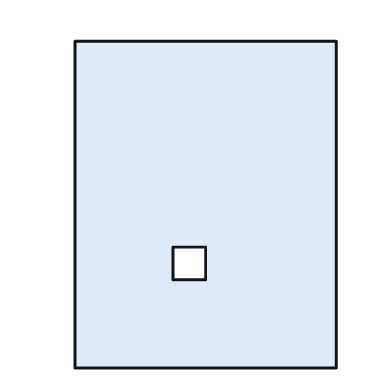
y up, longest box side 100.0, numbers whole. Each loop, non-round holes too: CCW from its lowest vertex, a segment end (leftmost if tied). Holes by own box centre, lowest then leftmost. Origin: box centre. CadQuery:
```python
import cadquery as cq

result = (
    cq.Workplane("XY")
    .moveTo(-40.0, -50.0)
    .lineTo(40.0, -50.0)
    .lineTo(40.0, 50.0)
    .lineTo(-40.0, 50.0)
    .close()
    .moveTo(-10.0, -23.0)
    .lineTo(0.0, -23.0)
    .lineTo(0.0, -13.0)
    .lineTo(-10.0, -13.0)
    .close()
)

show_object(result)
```